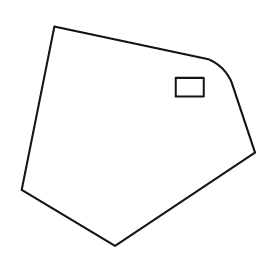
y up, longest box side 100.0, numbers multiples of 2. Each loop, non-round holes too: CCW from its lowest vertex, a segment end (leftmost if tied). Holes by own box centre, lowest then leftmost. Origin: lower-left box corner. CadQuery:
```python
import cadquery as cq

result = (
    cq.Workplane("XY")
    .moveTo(40.0, 0.0)
    .lineTo(100.0, 40.0)
    .lineTo(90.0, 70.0)
    .threePointArc((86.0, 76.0), (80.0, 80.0))
    .lineTo(14.0, 94.0)
    .lineTo(0.0, 24.0)
    .close()
    .moveTo(66.0, 64.0)
    .lineTo(78.0, 64.0)
    .lineTo(78.0, 72.0)
    .lineTo(66.0, 72.0)
    .close()
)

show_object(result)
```